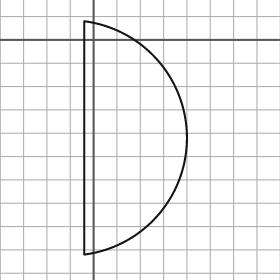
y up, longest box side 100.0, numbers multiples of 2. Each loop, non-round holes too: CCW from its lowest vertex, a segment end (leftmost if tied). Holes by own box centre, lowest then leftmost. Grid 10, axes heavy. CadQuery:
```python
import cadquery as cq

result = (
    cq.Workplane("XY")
    .moveTo(-4.0, -92.0)
    .threePointArc((40.0, -42.0), (-4.0, 8.0))
    .close()
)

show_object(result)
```